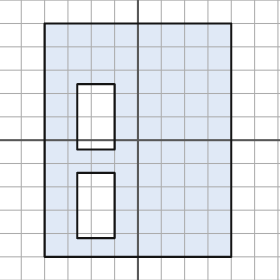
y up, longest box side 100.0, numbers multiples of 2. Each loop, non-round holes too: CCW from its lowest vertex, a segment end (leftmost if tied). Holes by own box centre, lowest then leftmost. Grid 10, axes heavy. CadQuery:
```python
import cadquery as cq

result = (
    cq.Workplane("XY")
    .moveTo(-40.0, -50.0)
    .lineTo(40.0, -50.0)
    .lineTo(40.0, 50.0)
    .lineTo(-40.0, 50.0)
    .close()
    .moveTo(-26.0, -42.0)
    .lineTo(-10.0, -42.0)
    .lineTo(-10.0, -14.0)
    .lineTo(-26.0, -14.0)
    .close()
    .moveTo(-26.0, -4.0)
    .lineTo(-10.0, -4.0)
    .lineTo(-10.0, 24.0)
    .lineTo(-26.0, 24.0)
    .close()
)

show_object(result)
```